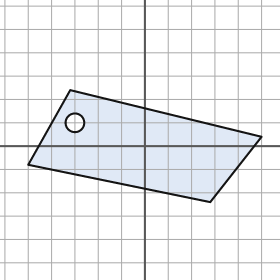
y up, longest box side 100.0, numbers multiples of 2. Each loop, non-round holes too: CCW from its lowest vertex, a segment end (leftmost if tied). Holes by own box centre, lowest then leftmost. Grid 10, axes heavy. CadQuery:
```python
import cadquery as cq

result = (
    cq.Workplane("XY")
    .moveTo(28.0, -24.0)
    .lineTo(50.0, 4.0)
    .lineTo(-32.0, 24.0)
    .lineTo(-50.0, -8.0)
    .close()
    .moveTo(-30.0, 10.0)
    .circle(4.0)
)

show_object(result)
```